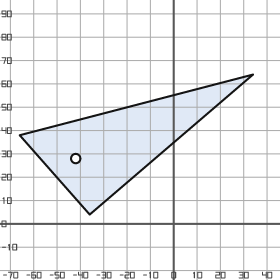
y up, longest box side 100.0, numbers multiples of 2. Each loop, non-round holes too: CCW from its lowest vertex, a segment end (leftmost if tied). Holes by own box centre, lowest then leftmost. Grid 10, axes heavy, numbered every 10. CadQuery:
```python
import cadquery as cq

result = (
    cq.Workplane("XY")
    .moveTo(-36.0, 4.0)
    .lineTo(34.0, 64.0)
    .lineTo(-66.0, 38.0)
    .close()
    .moveTo(-42.0, 28.0)
    .circle(2.0)
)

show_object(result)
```